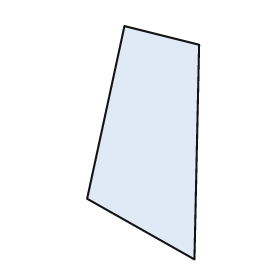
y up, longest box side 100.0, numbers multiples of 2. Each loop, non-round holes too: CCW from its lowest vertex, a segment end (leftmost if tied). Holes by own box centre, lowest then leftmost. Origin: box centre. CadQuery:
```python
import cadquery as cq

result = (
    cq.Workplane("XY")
    .moveTo(22.0, -50.0)
    .lineTo(24.0, 42.0)
    .lineTo(-8.0, 50.0)
    .lineTo(-24.0, -24.0)
    .close()
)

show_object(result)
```